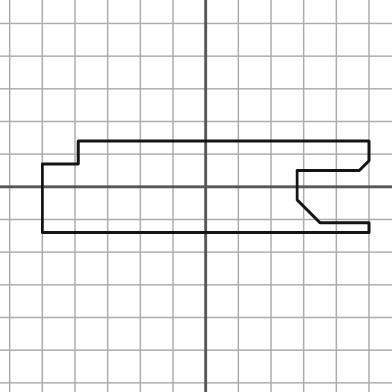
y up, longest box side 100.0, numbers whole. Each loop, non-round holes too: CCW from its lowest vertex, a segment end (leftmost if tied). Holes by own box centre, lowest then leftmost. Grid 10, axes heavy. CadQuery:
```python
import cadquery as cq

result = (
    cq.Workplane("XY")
    .moveTo(-50.0, -14.0)
    .lineTo(50.0, -14.0)
    .lineTo(50.0, -11.0)
    .lineTo(35.0, -11.0)
    .lineTo(28.0, -4.0)
    .lineTo(28.0, 5.0)
    .lineTo(47.0, 5.0)
    .lineTo(50.0, 8.0)
    .lineTo(50.0, 14.0)
    .lineTo(-39.0, 14.0)
    .lineTo(-39.0, 7.0)
    .lineTo(-50.0, 7.0)
    .close()
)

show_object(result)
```